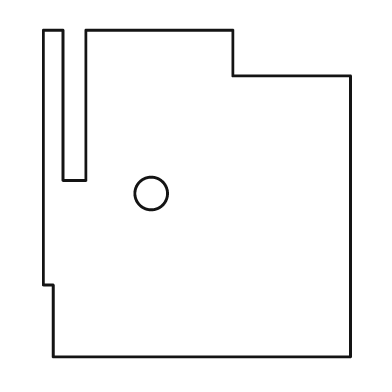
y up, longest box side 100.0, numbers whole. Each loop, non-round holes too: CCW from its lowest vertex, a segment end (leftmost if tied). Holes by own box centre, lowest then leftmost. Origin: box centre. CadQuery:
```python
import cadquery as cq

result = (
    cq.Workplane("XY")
    .moveTo(-44.0, -50.0)
    .lineTo(47.0, -50.0)
    .lineTo(47.0, 36.0)
    .lineTo(11.0, 36.0)
    .lineTo(11.0, 50.0)
    .lineTo(-34.0, 50.0)
    .lineTo(-34.0, 4.0)
    .lineTo(-41.0, 4.0)
    .lineTo(-41.0, 50.0)
    .lineTo(-47.0, 50.0)
    .lineTo(-47.0, -28.0)
    .lineTo(-44.0, -28.0)
    .close()
    .moveTo(-14.0, 0.0)
    .circle(5.0)
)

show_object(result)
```